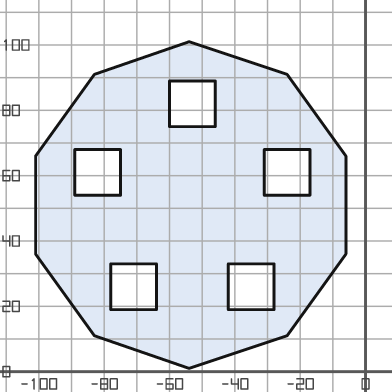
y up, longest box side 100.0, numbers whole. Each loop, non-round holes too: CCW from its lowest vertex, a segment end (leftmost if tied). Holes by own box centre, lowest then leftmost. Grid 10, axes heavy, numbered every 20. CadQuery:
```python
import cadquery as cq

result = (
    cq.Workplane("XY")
    .moveTo(-54.0, 1.0)
    .lineTo(-24.0, 11.0)
    .lineTo(-6.0, 36.0)
    .lineTo(-6.0, 66.0)
    .lineTo(-24.0, 91.0)
    .lineTo(-54.0, 101.0)
    .lineTo(-83.0, 91.0)
    .lineTo(-101.0, 66.0)
    .lineTo(-101.0, 36.0)
    .lineTo(-83.0, 11.0)
    .close()
    .moveTo(-78.0, 19.0)
    .lineTo(-64.0, 19.0)
    .lineTo(-64.0, 33.0)
    .lineTo(-78.0, 33.0)
    .close()
    .moveTo(-42.0, 19.0)
    .lineTo(-28.0, 19.0)
    .lineTo(-28.0, 33.0)
    .lineTo(-42.0, 33.0)
    .close()
    .moveTo(-89.0, 54.0)
    .lineTo(-75.0, 54.0)
    .lineTo(-75.0, 68.0)
    .lineTo(-89.0, 68.0)
    .close()
    .moveTo(-31.0, 54.0)
    .lineTo(-17.0, 54.0)
    .lineTo(-17.0, 68.0)
    .lineTo(-31.0, 68.0)
    .close()
    .moveTo(-60.0, 75.0)
    .lineTo(-46.0, 75.0)
    .lineTo(-46.0, 89.0)
    .lineTo(-60.0, 89.0)
    .close()
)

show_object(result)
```